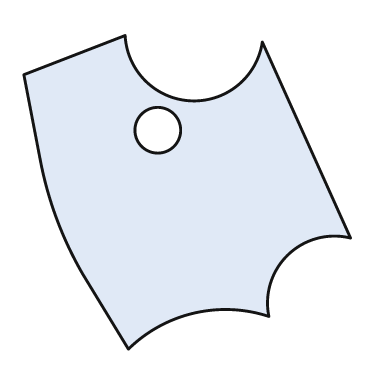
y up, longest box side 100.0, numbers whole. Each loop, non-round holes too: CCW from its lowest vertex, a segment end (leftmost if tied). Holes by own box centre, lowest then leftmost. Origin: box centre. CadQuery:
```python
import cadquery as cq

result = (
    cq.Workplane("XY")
    .moveTo(-18.0, -48.0)
    .threePointArc((2.0, -37.0), (25.0, -38.0))
    .threePointArc((31.0, -19.0), (50.0, -14.0))
    .lineTo(23.0, 46.0)
    .threePointArc((1.0, 28.0), (-19.0, 48.0))
    .lineTo(-50.0, 36.0)
    .lineTo(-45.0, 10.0)
    .threePointArc((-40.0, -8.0), (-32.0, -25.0))
    .close()
    .moveTo(-9.0, 19.0)
    .circle(7.0)
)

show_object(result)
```